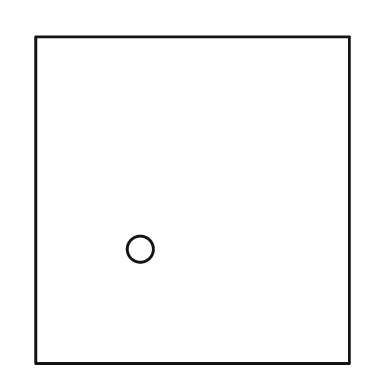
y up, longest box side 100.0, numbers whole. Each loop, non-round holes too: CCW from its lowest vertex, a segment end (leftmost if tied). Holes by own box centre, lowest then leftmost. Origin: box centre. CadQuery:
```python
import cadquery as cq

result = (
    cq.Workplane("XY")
    .moveTo(-48.0, -50.0)
    .lineTo(48.0, -50.0)
    .lineTo(48.0, 50.0)
    .lineTo(-48.0, 50.0)
    .close()
    .moveTo(-16.0, -15.0)
    .circle(4.0)
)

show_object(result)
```